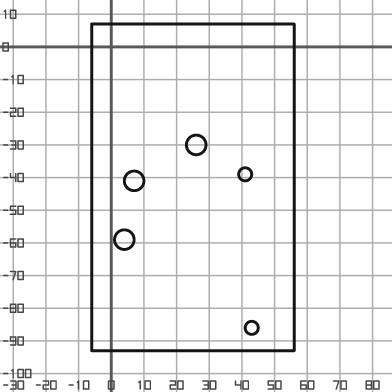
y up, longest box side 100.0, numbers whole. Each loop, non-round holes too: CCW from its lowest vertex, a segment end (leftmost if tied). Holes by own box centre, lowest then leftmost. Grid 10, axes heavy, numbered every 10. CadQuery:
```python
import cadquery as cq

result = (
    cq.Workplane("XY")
    .moveTo(-6.0, -93.0)
    .lineTo(56.0, -93.0)
    .lineTo(56.0, 7.0)
    .lineTo(-6.0, 7.0)
    .close()
    .moveTo(43.0, -86.0)
    .circle(2.0)
    .moveTo(4.0, -59.0)
    .circle(3.0)
    .moveTo(7.0, -41.0)
    .circle(3.0)
    .moveTo(41.0, -39.0)
    .circle(2.0)
    .moveTo(26.0, -30.0)
    .circle(3.0)
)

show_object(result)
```